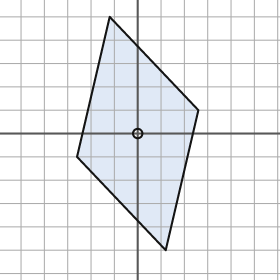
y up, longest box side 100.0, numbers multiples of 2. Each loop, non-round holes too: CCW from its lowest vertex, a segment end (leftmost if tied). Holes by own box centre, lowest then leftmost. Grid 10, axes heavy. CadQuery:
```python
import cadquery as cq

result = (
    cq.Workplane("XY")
    .moveTo(12.0, -50.0)
    .lineTo(26.0, 10.0)
    .lineTo(-12.0, 50.0)
    .lineTo(-26.0, -10.0)
    .close()
    .moveTo(0.0, 0.0)
    .circle(2.0)
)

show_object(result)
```